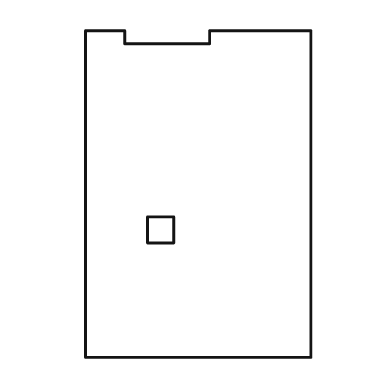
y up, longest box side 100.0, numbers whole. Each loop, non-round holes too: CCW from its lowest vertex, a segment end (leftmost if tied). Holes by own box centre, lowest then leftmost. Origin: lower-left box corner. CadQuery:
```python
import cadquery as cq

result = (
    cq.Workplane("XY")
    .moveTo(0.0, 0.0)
    .lineTo(69.0, 0.0)
    .lineTo(69.0, 100.0)
    .lineTo(38.0, 100.0)
    .lineTo(38.0, 96.0)
    .lineTo(12.0, 96.0)
    .lineTo(12.0, 100.0)
    .lineTo(0.0, 100.0)
    .close()
    .moveTo(19.0, 35.0)
    .lineTo(27.0, 35.0)
    .lineTo(27.0, 43.0)
    .lineTo(19.0, 43.0)
    .close()
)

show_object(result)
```